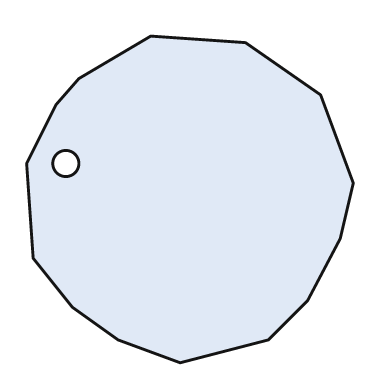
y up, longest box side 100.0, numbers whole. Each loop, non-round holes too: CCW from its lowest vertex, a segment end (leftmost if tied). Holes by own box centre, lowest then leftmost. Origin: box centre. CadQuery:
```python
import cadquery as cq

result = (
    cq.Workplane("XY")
    .moveTo(-3.0, -50.0)
    .lineTo(24.0, -43.0)
    .lineTo(36.0, -31.0)
    .lineTo(46.0, -12.0)
    .lineTo(50.0, 5.0)
    .lineTo(40.0, 32.0)
    .lineTo(17.0, 48.0)
    .lineTo(-12.0, 50.0)
    .lineTo(-34.0, 37.0)
    .lineTo(-41.0, 29.0)
    .lineTo(-50.0, 11.0)
    .lineTo(-48.0, -18.0)
    .lineTo(-36.0, -33.0)
    .lineTo(-22.0, -43.0)
    .close()
    .moveTo(-38.0, 11.0)
    .circle(4.0)
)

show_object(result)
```